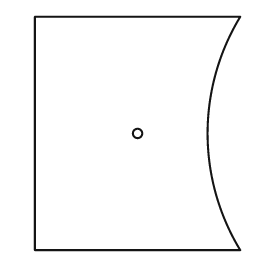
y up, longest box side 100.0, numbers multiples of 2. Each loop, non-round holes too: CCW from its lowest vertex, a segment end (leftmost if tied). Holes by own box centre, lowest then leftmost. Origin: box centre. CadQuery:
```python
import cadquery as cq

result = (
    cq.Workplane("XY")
    .moveTo(-44.0, -50.0)
    .lineTo(44.0, -50.0)
    .threePointArc((30.0, 0.0), (44.0, 50.0))
    .lineTo(-44.0, 50.0)
    .close()
    .moveTo(0.0, 0.0)
    .circle(2.0)
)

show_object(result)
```